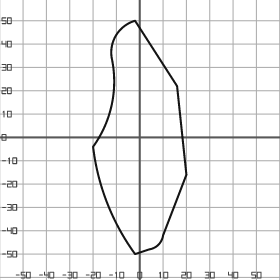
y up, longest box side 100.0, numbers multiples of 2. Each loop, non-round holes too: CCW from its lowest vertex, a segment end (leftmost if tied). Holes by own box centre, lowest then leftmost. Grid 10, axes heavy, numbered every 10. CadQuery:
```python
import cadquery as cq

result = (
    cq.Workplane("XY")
    .moveTo(-2.0, -50.0)
    .lineTo(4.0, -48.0)
    .threePointArc((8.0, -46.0), (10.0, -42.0))
    .lineTo(20.0, -16.0)
    .lineTo(16.0, 22.0)
    .lineTo(-2.0, 50.0)
    .threePointArc((-10.0, 44.0), (-12.0, 34.0))
    .threePointArc((-12.0, 14.0), (-20.0, -4.0))
    .threePointArc((-14.0, -28.0), (-2.0, -50.0))
    .close()
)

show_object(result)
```